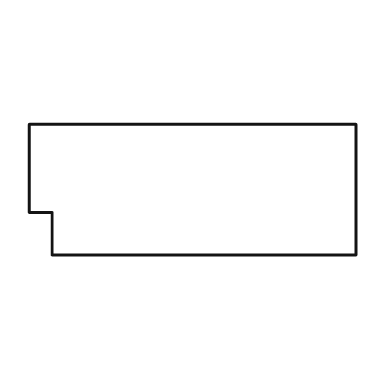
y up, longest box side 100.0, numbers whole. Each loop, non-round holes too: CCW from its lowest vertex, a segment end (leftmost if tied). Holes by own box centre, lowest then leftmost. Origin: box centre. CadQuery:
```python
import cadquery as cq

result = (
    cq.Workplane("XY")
    .moveTo(-43.0, -20.0)
    .lineTo(50.0, -20.0)
    .lineTo(50.0, 20.0)
    .lineTo(-50.0, 20.0)
    .lineTo(-50.0, -7.0)
    .lineTo(-43.0, -7.0)
    .close()
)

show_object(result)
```